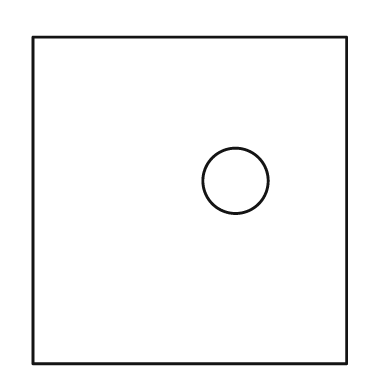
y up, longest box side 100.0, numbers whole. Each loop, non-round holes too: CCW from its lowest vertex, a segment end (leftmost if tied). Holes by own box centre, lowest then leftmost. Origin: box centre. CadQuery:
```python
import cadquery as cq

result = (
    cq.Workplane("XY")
    .moveTo(-48.0, -50.0)
    .lineTo(48.0, -50.0)
    .lineTo(48.0, 50.0)
    .lineTo(-48.0, 50.0)
    .close()
    .moveTo(14.0, 6.0)
    .circle(10.0)
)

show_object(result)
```